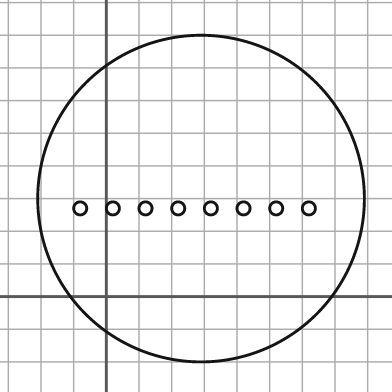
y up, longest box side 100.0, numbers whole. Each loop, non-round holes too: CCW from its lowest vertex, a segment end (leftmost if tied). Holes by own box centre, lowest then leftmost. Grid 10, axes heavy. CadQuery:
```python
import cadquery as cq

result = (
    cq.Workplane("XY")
    .moveTo(29.0, 30.0)
    .circle(50.0)
    .moveTo(-8.0, 27.0)
    .circle(2.0)
    .moveTo(2.0, 27.0)
    .circle(2.0)
    .moveTo(12.0, 27.0)
    .circle(2.0)
    .moveTo(22.0, 27.0)
    .circle(2.0)
    .moveTo(32.0, 27.0)
    .circle(2.0)
    .moveTo(42.0, 27.0)
    .circle(2.0)
    .moveTo(52.0, 27.0)
    .circle(2.0)
    .moveTo(62.0, 27.0)
    .circle(2.0)
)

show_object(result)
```